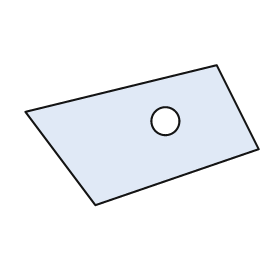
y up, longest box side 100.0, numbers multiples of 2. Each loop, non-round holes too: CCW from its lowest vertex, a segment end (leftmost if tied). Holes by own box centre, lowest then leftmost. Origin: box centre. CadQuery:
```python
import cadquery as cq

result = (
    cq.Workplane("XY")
    .moveTo(-20.0, -30.0)
    .lineTo(50.0, -6.0)
    .lineTo(32.0, 30.0)
    .lineTo(-50.0, 10.0)
    .close()
    .moveTo(10.0, 6.0)
    .circle(6.0)
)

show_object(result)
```